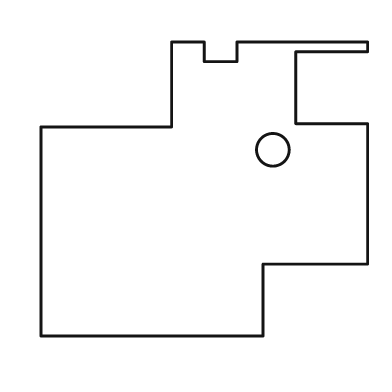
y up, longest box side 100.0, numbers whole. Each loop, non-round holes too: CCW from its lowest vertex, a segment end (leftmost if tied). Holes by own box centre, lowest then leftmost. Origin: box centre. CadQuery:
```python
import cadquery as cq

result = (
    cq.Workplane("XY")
    .moveTo(-50.0, -45.0)
    .lineTo(18.0, -45.0)
    .lineTo(18.0, -23.0)
    .lineTo(50.0, -23.0)
    .lineTo(50.0, 20.0)
    .lineTo(28.0, 20.0)
    .lineTo(28.0, 42.0)
    .lineTo(50.0, 42.0)
    .lineTo(50.0, 45.0)
    .lineTo(10.0, 45.0)
    .lineTo(10.0, 39.0)
    .lineTo(0.0, 39.0)
    .lineTo(0.0, 45.0)
    .lineTo(-10.0, 45.0)
    .lineTo(-10.0, 19.0)
    .lineTo(-50.0, 19.0)
    .close()
    .moveTo(21.0, 12.0)
    .circle(5.0)
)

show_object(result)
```